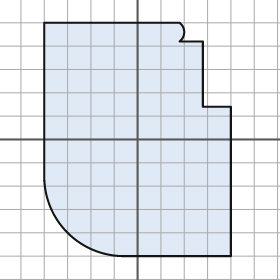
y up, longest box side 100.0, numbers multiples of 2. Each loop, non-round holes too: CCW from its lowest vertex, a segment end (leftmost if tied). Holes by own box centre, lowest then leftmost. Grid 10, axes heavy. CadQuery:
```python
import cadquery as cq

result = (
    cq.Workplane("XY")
    .moveTo(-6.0, -50.0)
    .lineTo(40.0, -50.0)
    .lineTo(40.0, 14.0)
    .lineTo(28.0, 14.0)
    .lineTo(28.0, 42.0)
    .lineTo(18.0, 42.0)
    .threePointArc((20.0, 46.0), (18.0, 50.0))
    .lineTo(-40.0, 50.0)
    .lineTo(-40.0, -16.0)
    .threePointArc((-30.0, -40.0), (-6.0, -50.0))
    .close()
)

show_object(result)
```